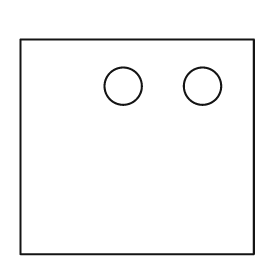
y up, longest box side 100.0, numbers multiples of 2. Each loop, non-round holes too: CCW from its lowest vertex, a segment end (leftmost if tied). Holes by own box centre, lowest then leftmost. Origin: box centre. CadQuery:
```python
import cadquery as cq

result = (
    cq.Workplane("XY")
    .moveTo(-50.0, -46.0)
    .lineTo(50.0, -46.0)
    .lineTo(50.0, 46.0)
    .lineTo(-50.0, 46.0)
    .close()
    .moveTo(-6.0, 26.0)
    .circle(8.0)
    .moveTo(28.0, 26.0)
    .circle(8.0)
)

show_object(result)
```